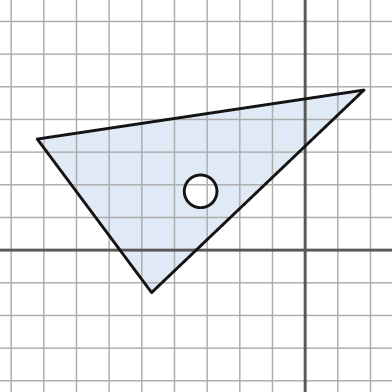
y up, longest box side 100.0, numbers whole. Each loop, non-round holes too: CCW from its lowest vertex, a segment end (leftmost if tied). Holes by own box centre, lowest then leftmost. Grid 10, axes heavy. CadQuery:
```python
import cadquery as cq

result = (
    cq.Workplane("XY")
    .moveTo(-47.0, -13.0)
    .lineTo(18.0, 49.0)
    .lineTo(-82.0, 34.0)
    .close()
    .moveTo(-32.0, 18.0)
    .circle(5.0)
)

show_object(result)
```